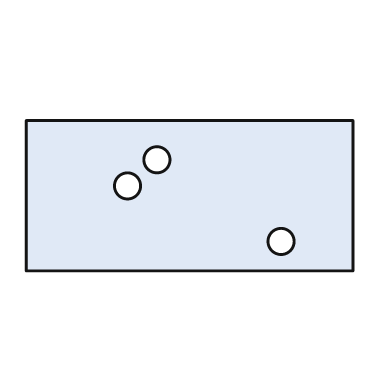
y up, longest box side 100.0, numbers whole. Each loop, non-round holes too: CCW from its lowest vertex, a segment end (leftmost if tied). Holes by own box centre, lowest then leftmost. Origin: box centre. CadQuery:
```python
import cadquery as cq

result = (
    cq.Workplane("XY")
    .moveTo(-50.0, -23.0)
    .lineTo(50.0, -23.0)
    .lineTo(50.0, 23.0)
    .lineTo(-50.0, 23.0)
    .close()
    .moveTo(28.0, -14.0)
    .circle(4.0)
    .moveTo(-19.0, 3.0)
    .circle(4.0)
    .moveTo(-10.0, 11.0)
    .circle(4.0)
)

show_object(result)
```